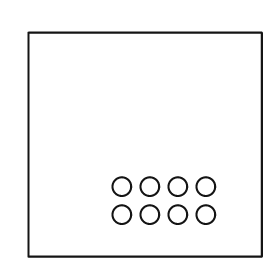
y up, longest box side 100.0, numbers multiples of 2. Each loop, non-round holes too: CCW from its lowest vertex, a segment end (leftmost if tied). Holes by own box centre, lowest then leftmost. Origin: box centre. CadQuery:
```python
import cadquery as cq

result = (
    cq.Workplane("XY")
    .moveTo(-50.0, -48.0)
    .lineTo(50.0, -48.0)
    .lineTo(50.0, 48.0)
    .lineTo(-50.0, 48.0)
    .close()
    .moveTo(-10.0, -30.0)
    .circle(4.0)
    .moveTo(2.0, -30.0)
    .circle(4.0)
    .moveTo(14.0, -30.0)
    .circle(4.0)
    .moveTo(26.0, -30.0)
    .circle(4.0)
    .moveTo(-10.0, -18.0)
    .circle(4.0)
    .moveTo(2.0, -18.0)
    .circle(4.0)
    .moveTo(14.0, -18.0)
    .circle(4.0)
    .moveTo(26.0, -18.0)
    .circle(4.0)
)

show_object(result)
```